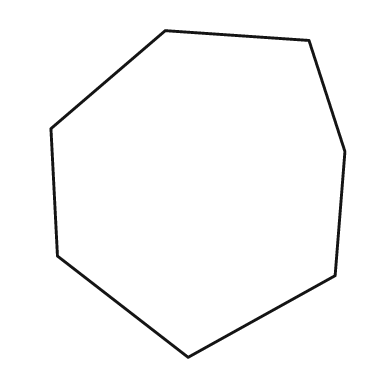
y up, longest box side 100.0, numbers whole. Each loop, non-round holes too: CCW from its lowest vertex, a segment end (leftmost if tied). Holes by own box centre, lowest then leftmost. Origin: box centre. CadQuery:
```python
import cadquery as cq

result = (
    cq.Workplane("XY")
    .moveTo(-3.0, -50.0)
    .lineTo(42.0, -25.0)
    .lineTo(45.0, 13.0)
    .lineTo(34.0, 47.0)
    .lineTo(-10.0, 50.0)
    .lineTo(-45.0, 20.0)
    .lineTo(-43.0, -19.0)
    .close()
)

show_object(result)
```